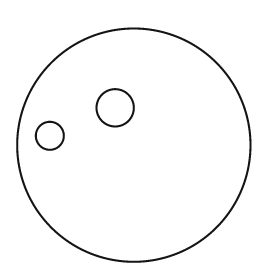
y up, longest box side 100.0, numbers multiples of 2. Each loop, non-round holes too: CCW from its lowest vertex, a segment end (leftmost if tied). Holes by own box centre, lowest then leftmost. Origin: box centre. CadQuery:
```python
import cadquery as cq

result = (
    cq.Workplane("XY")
    .moveTo(0.0, 0.0)
    .circle(50.0)
    .moveTo(-36.0, 4.0)
    .circle(6.0)
    .moveTo(-8.0, 16.0)
    .circle(8.0)
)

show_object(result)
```